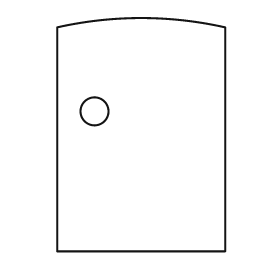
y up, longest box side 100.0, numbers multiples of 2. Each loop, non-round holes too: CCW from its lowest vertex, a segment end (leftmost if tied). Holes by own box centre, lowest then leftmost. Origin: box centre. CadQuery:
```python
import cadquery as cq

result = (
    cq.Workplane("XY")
    .moveTo(-36.0, -50.0)
    .lineTo(36.0, -50.0)
    .lineTo(36.0, 46.0)
    .threePointArc((0.0, 50.0), (-36.0, 46.0))
    .close()
    .moveTo(-20.0, 10.0)
    .circle(6.0)
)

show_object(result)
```